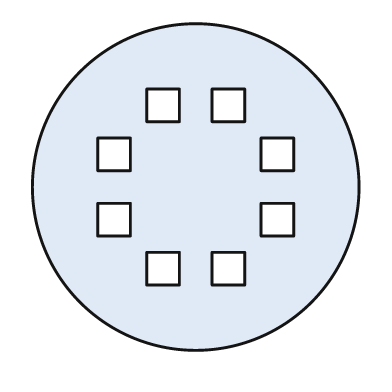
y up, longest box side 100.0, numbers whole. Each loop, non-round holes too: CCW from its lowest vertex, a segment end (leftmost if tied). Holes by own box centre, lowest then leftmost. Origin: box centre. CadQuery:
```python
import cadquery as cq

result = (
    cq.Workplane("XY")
    .moveTo(0.0, 0.0)
    .circle(50.0)
    .moveTo(-15.0, -30.0)
    .lineTo(-5.0, -30.0)
    .lineTo(-5.0, -20.0)
    .lineTo(-15.0, -20.0)
    .close()
    .moveTo(5.0, -30.0)
    .lineTo(15.0, -30.0)
    .lineTo(15.0, -20.0)
    .lineTo(5.0, -20.0)
    .close()
    .moveTo(-30.0, -15.0)
    .lineTo(-20.0, -15.0)
    .lineTo(-20.0, -5.0)
    .lineTo(-30.0, -5.0)
    .close()
    .moveTo(20.0, -15.0)
    .lineTo(30.0, -15.0)
    .lineTo(30.0, -5.0)
    .lineTo(20.0, -5.0)
    .close()
    .moveTo(-30.0, 5.0)
    .lineTo(-20.0, 5.0)
    .lineTo(-20.0, 15.0)
    .lineTo(-30.0, 15.0)
    .close()
    .moveTo(20.0, 5.0)
    .lineTo(30.0, 5.0)
    .lineTo(30.0, 15.0)
    .lineTo(20.0, 15.0)
    .close()
    .moveTo(-15.0, 20.0)
    .lineTo(-5.0, 20.0)
    .lineTo(-5.0, 30.0)
    .lineTo(-15.0, 30.0)
    .close()
    .moveTo(5.0, 20.0)
    .lineTo(15.0, 20.0)
    .lineTo(15.0, 30.0)
    .lineTo(5.0, 30.0)
    .close()
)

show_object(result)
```